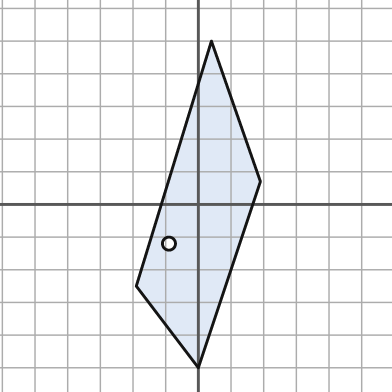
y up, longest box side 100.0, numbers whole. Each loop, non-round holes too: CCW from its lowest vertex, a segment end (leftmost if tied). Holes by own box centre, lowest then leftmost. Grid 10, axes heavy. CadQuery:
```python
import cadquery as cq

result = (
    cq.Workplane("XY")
    .moveTo(0.0, -50.0)
    .lineTo(19.0, 7.0)
    .lineTo(4.0, 50.0)
    .lineTo(-19.0, -25.0)
    .close()
    .moveTo(-9.0, -12.0)
    .circle(2.0)
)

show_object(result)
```